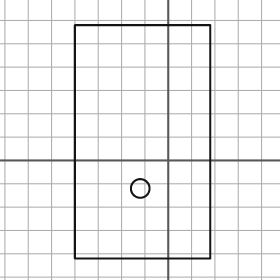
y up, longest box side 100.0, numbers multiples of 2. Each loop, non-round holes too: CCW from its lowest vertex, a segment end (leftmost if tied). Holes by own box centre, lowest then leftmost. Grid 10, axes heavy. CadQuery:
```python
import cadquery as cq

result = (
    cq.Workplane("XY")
    .moveTo(-40.0, -42.0)
    .lineTo(18.0, -42.0)
    .lineTo(18.0, 58.0)
    .lineTo(-40.0, 58.0)
    .close()
    .moveTo(-12.0, -12.0)
    .circle(4.0)
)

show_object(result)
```